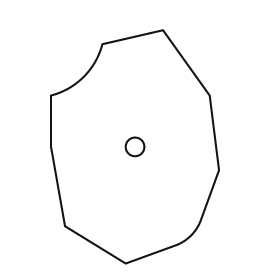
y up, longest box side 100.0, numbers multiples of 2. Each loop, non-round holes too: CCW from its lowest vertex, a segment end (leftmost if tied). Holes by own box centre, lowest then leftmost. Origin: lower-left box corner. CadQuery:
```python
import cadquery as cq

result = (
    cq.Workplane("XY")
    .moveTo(32.0, 0.0)
    .lineTo(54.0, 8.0)
    .threePointArc((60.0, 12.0), (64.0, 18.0))
    .lineTo(72.0, 40.0)
    .lineTo(68.0, 72.0)
    .lineTo(48.0, 100.0)
    .lineTo(22.0, 94.0)
    .threePointArc((14.0, 80.0), (0.0, 72.0))
    .lineTo(0.0, 50.0)
    .lineTo(6.0, 16.0)
    .close()
    .moveTo(36.0, 50.0)
    .circle(4.0)
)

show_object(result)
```